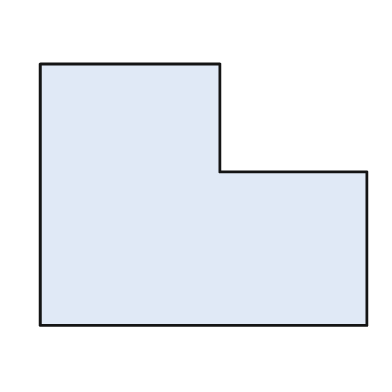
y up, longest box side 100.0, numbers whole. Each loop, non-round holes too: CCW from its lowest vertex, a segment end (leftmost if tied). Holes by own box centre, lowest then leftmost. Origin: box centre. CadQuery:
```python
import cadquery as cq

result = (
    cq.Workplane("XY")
    .moveTo(-50.0, -40.0)
    .lineTo(50.0, -40.0)
    .lineTo(50.0, 7.0)
    .lineTo(5.0, 7.0)
    .lineTo(5.0, 40.0)
    .lineTo(-50.0, 40.0)
    .close()
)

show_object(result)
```